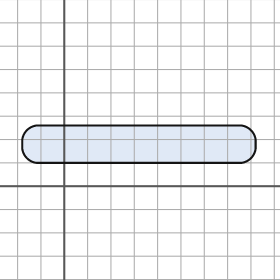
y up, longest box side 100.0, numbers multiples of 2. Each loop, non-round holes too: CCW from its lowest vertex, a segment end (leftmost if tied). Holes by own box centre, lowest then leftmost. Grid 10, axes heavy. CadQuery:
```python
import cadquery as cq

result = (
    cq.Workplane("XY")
    .moveTo(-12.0, 10.0)
    .lineTo(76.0, 10.0)
    .threePointArc((80.0, 12.0), (82.0, 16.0))
    .lineTo(82.0, 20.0)
    .threePointArc((80.0, 24.0), (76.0, 26.0))
    .lineTo(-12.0, 26.0)
    .threePointArc((-16.0, 24.0), (-18.0, 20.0))
    .lineTo(-18.0, 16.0)
    .threePointArc((-16.0, 12.0), (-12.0, 10.0))
    .close()
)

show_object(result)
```